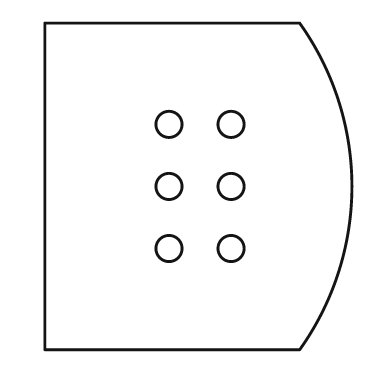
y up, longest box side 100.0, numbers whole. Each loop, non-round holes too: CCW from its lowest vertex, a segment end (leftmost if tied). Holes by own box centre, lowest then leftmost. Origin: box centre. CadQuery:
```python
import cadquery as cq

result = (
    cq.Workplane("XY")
    .moveTo(-47.0, -50.0)
    .lineTo(31.0, -50.0)
    .threePointArc((47.0, 0.0), (31.0, 50.0))
    .lineTo(-47.0, 50.0)
    .close()
    .moveTo(-9.0, -19.0)
    .circle(4.0)
    .moveTo(10.0, -19.0)
    .circle(4.0)
    .moveTo(-9.0, 0.0)
    .circle(4.0)
    .moveTo(10.0, 0.0)
    .circle(4.0)
    .moveTo(-9.0, 19.0)
    .circle(4.0)
    .moveTo(10.0, 19.0)
    .circle(4.0)
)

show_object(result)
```